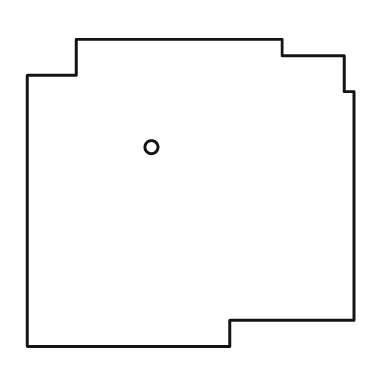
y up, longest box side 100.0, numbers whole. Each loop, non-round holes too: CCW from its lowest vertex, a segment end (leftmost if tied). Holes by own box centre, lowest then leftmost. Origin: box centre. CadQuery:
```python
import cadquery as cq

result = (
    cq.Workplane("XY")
    .moveTo(-50.0, -47.0)
    .lineTo(12.0, -47.0)
    .lineTo(12.0, -39.0)
    .lineTo(50.0, -39.0)
    .lineTo(50.0, 31.0)
    .lineTo(47.0, 31.0)
    .lineTo(47.0, 42.0)
    .lineTo(28.0, 42.0)
    .lineTo(28.0, 47.0)
    .lineTo(-35.0, 47.0)
    .lineTo(-35.0, 36.0)
    .lineTo(-50.0, 36.0)
    .close()
    .moveTo(-12.0, 14.0)
    .circle(2.0)
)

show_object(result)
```